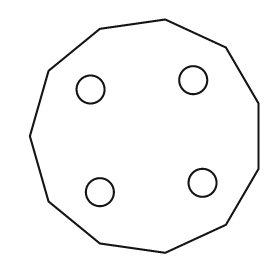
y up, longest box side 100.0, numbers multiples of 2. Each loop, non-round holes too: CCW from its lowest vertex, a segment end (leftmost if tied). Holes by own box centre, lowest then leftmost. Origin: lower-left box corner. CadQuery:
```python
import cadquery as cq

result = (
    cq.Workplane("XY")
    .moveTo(58.0, 0.0)
    .lineTo(84.0, 12.0)
    .lineTo(98.0, 36.0)
    .lineTo(98.0, 64.0)
    .lineTo(84.0, 88.0)
    .lineTo(58.0, 100.0)
    .lineTo(30.0, 96.0)
    .lineTo(8.0, 78.0)
    .lineTo(0.0, 50.0)
    .lineTo(8.0, 22.0)
    .lineTo(30.0, 4.0)
    .close()
    .moveTo(30.0, 26.0)
    .circle(6.0)
    .moveTo(74.0, 30.0)
    .circle(6.0)
    .moveTo(26.0, 70.0)
    .circle(6.0)
    .moveTo(70.0, 74.0)
    .circle(6.0)
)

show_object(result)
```